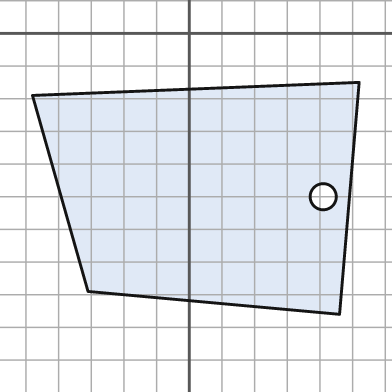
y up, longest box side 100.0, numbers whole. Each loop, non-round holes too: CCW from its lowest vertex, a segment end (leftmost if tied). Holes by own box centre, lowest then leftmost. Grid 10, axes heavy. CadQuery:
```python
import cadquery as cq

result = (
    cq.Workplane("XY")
    .moveTo(46.0, -86.0)
    .lineTo(52.0, -15.0)
    .lineTo(-48.0, -19.0)
    .lineTo(-31.0, -79.0)
    .close()
    .moveTo(41.0, -50.0)
    .circle(4.0)
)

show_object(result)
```